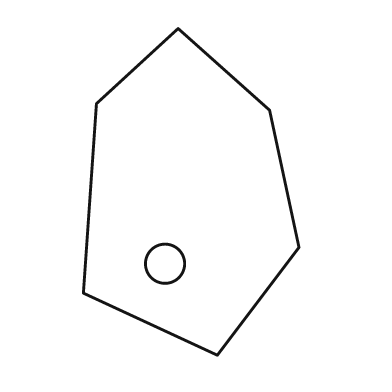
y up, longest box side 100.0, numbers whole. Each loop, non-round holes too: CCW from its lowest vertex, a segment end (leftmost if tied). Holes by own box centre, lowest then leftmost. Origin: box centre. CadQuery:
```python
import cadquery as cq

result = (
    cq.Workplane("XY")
    .moveTo(8.0, -50.0)
    .lineTo(33.0, -17.0)
    .lineTo(24.0, 25.0)
    .lineTo(-4.0, 50.0)
    .lineTo(-29.0, 27.0)
    .lineTo(-33.0, -31.0)
    .close()
    .moveTo(-8.0, -22.0)
    .circle(6.0)
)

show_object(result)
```